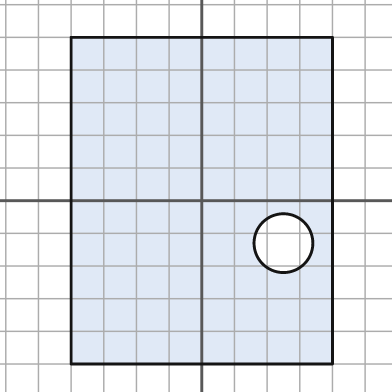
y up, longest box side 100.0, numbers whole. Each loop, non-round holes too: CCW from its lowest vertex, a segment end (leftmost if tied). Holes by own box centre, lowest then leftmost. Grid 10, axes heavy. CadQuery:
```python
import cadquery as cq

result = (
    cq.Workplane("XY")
    .moveTo(-40.0, -50.0)
    .lineTo(40.0, -50.0)
    .lineTo(40.0, 50.0)
    .lineTo(-40.0, 50.0)
    .close()
    .moveTo(25.0, -13.0)
    .circle(9.0)
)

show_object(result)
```